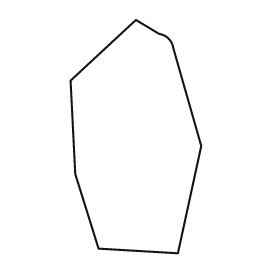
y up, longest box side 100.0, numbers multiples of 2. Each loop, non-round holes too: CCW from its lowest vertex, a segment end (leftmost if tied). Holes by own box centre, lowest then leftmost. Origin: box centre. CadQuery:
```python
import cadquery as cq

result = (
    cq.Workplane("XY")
    .moveTo(18.0, -50.0)
    .lineTo(28.0, -4.0)
    .lineTo(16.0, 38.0)
    .threePointArc((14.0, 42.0), (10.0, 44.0))
    .lineTo(0.0, 50.0)
    .lineTo(-28.0, 24.0)
    .lineTo(-26.0, -16.0)
    .lineTo(-16.0, -48.0)
    .close()
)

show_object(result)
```